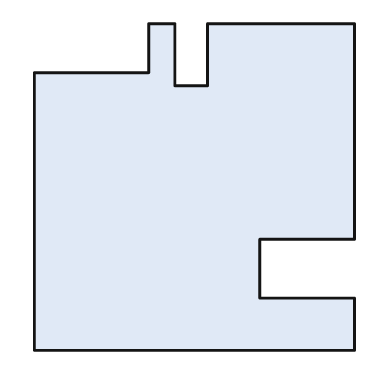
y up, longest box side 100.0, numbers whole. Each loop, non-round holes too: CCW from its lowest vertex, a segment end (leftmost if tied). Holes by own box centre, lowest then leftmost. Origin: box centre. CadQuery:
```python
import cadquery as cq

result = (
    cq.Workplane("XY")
    .moveTo(-49.0, -50.0)
    .lineTo(49.0, -50.0)
    .lineTo(49.0, -34.0)
    .lineTo(20.0, -34.0)
    .lineTo(20.0, -16.0)
    .lineTo(49.0, -16.0)
    .lineTo(49.0, 50.0)
    .lineTo(4.0, 50.0)
    .lineTo(4.0, 31.0)
    .lineTo(-6.0, 31.0)
    .lineTo(-6.0, 50.0)
    .lineTo(-14.0, 50.0)
    .lineTo(-14.0, 35.0)
    .lineTo(-49.0, 35.0)
    .close()
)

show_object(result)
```